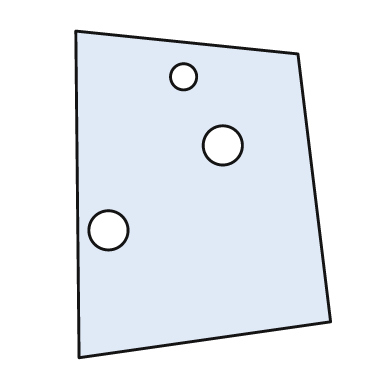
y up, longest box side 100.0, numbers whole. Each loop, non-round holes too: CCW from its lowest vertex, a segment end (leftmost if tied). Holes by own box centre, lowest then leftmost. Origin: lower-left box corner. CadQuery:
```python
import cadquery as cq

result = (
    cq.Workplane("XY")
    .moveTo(1.0, 0.0)
    .lineTo(78.0, 11.0)
    .lineTo(68.0, 93.0)
    .lineTo(0.0, 100.0)
    .close()
    .moveTo(10.0, 39.0)
    .circle(6.0)
    .moveTo(45.0, 65.0)
    .circle(6.0)
    .moveTo(33.0, 86.0)
    .circle(4.0)
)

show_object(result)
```